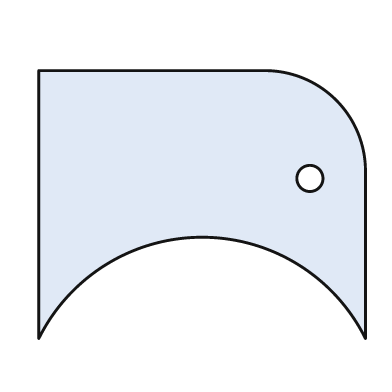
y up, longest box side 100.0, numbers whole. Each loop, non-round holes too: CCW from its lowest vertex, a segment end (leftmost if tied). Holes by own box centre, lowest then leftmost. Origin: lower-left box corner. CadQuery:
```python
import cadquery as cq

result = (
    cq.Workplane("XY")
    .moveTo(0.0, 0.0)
    .threePointArc((50.0, 31.0), (100.0, 0.0))
    .lineTo(100.0, 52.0)
    .threePointArc((91.0, 73.0), (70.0, 82.0))
    .lineTo(0.0, 82.0)
    .close()
    .moveTo(83.0, 49.0)
    .circle(4.0)
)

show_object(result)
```